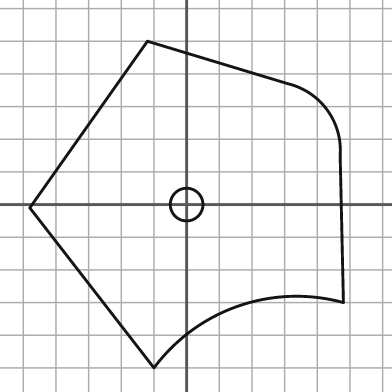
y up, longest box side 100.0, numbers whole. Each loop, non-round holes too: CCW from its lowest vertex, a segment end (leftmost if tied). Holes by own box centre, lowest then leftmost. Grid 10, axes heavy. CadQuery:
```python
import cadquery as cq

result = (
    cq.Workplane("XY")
    .moveTo(-10.0, -50.0)
    .threePointArc((16.0, -31.0), (48.0, -30.0))
    .lineTo(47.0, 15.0)
    .threePointArc((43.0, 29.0), (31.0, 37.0))
    .lineTo(-12.0, 50.0)
    .lineTo(-48.0, -1.0)
    .close()
    .moveTo(0.0, 0.0)
    .circle(5.0)
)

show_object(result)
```